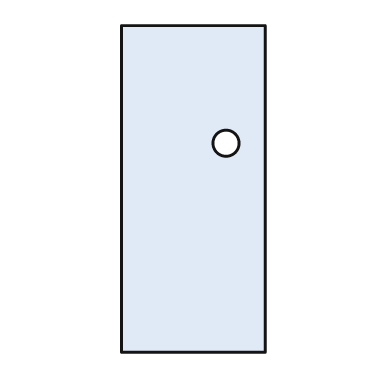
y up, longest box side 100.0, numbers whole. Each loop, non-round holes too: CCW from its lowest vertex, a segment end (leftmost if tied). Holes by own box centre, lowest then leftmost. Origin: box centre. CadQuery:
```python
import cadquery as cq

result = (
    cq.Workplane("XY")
    .moveTo(-22.0, -50.0)
    .lineTo(22.0, -50.0)
    .lineTo(22.0, 50.0)
    .lineTo(-22.0, 50.0)
    .close()
    .moveTo(10.0, 14.0)
    .circle(4.0)
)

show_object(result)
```